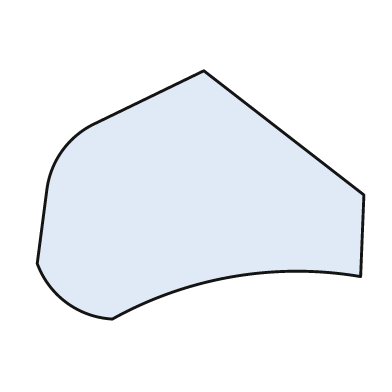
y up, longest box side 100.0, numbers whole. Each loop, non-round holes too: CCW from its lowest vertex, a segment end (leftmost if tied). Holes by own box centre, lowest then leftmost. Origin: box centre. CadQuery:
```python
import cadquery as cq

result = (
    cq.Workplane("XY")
    .moveTo(-27.0, -38.0)
    .threePointArc((10.0, -25.0), (49.0, -25.0))
    .lineTo(50.0, 0.0)
    .lineTo(1.0, 38.0)
    .lineTo(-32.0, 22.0)
    .threePointArc((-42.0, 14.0), (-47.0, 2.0))
    .lineTo(-50.0, -21.0)
    .threePointArc((-41.0, -33.0), (-27.0, -38.0))
    .close()
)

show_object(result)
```